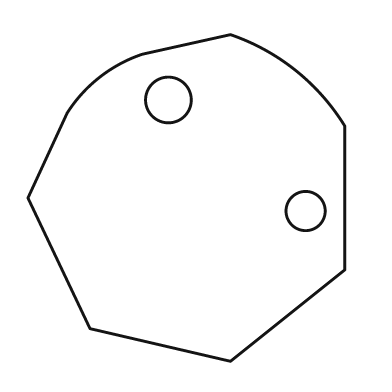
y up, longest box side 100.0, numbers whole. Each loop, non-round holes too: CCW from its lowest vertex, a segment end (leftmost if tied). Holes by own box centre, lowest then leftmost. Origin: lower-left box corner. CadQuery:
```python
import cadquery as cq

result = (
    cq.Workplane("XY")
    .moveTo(62.0, 0.0)
    .lineTo(97.0, 28.0)
    .lineTo(97.0, 72.0)
    .threePointArc((82.0, 89.0), (62.0, 100.0))
    .lineTo(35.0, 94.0)
    .threePointArc((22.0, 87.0), (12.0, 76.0))
    .lineTo(0.0, 50.0)
    .lineTo(19.0, 10.0)
    .close()
    .moveTo(85.0, 46.0)
    .circle(6.0)
    .moveTo(43.0, 80.0)
    .circle(7.0)
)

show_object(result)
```